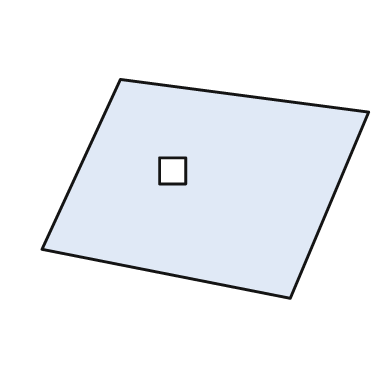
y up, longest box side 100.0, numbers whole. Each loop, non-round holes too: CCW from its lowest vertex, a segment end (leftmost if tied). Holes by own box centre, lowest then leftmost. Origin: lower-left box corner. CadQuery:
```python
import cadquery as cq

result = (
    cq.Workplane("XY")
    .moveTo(76.0, 0.0)
    .lineTo(100.0, 57.0)
    .lineTo(24.0, 67.0)
    .lineTo(0.0, 15.0)
    .close()
    .moveTo(36.0, 35.0)
    .lineTo(44.0, 35.0)
    .lineTo(44.0, 43.0)
    .lineTo(36.0, 43.0)
    .close()
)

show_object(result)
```